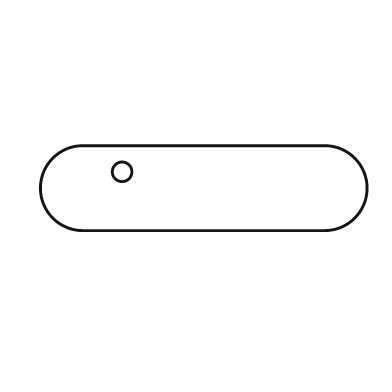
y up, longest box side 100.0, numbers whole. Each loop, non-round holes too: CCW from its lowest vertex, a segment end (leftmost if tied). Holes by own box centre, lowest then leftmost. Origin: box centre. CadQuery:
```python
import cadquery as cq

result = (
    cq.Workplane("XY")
    .moveTo(-37.0, -13.0)
    .lineTo(37.0, -13.0)
    .threePointArc((50.0, 0.0), (37.0, 13.0))
    .lineTo(-37.0, 13.0)
    .threePointArc((-50.0, 0.0), (-37.0, -13.0))
    .close()
    .moveTo(-25.0, 5.0)
    .circle(3.0)
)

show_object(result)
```